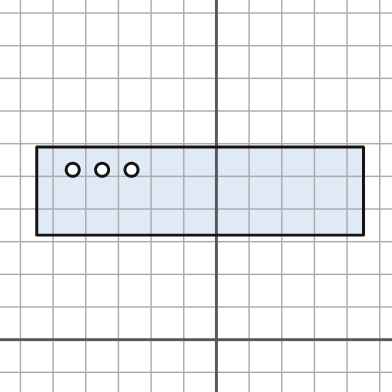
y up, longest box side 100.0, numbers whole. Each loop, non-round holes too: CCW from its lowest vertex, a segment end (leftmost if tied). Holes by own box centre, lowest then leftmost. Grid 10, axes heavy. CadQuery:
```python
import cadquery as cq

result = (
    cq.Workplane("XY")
    .moveTo(-55.0, 32.0)
    .lineTo(45.0, 32.0)
    .lineTo(45.0, 59.0)
    .lineTo(-55.0, 59.0)
    .close()
    .moveTo(-44.0, 52.0)
    .circle(2.0)
    .moveTo(-35.0, 52.0)
    .circle(2.0)
    .moveTo(-26.0, 52.0)
    .circle(2.0)
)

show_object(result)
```